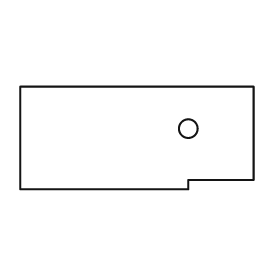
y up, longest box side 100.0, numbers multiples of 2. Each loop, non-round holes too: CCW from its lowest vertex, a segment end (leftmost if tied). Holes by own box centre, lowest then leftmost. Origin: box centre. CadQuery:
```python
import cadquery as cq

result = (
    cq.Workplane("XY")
    .moveTo(-50.0, -22.0)
    .lineTo(22.0, -22.0)
    .lineTo(22.0, -18.0)
    .lineTo(50.0, -18.0)
    .lineTo(50.0, 22.0)
    .lineTo(-50.0, 22.0)
    .close()
    .moveTo(22.0, 4.0)
    .circle(4.0)
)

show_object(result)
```